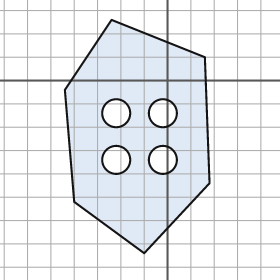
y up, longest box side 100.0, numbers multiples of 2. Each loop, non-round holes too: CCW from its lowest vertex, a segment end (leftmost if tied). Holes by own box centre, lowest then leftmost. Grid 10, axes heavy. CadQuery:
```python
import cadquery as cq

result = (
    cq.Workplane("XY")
    .moveTo(-10.0, -74.0)
    .lineTo(18.0, -44.0)
    .lineTo(16.0, 10.0)
    .lineTo(-24.0, 26.0)
    .lineTo(-44.0, -4.0)
    .lineTo(-40.0, -52.0)
    .close()
    .moveTo(-22.0, -34.0)
    .circle(6.0)
    .moveTo(-2.0, -34.0)
    .circle(6.0)
    .moveTo(-22.0, -14.0)
    .circle(6.0)
    .moveTo(-2.0, -14.0)
    .circle(6.0)
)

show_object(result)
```